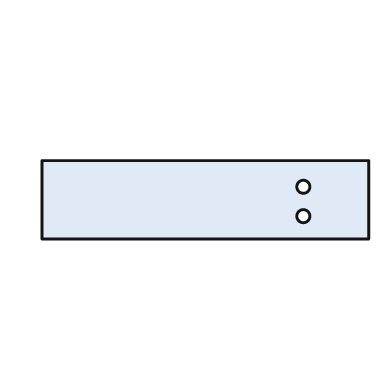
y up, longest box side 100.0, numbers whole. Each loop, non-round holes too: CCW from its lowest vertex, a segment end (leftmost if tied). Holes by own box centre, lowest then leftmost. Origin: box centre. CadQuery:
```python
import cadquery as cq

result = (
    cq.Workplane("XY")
    .moveTo(-50.0, -12.0)
    .lineTo(50.0, -12.0)
    .lineTo(50.0, 12.0)
    .lineTo(-50.0, 12.0)
    .close()
    .moveTo(30.0, -5.0)
    .circle(2.0)
    .moveTo(30.0, 4.0)
    .circle(2.0)
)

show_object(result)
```